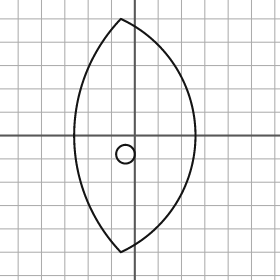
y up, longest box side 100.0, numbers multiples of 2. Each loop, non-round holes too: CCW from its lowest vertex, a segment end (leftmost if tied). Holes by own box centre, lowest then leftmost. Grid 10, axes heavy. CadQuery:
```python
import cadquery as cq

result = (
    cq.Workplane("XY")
    .moveTo(-6.0, -50.0)
    .threePointArc((26.0, 0.0), (-6.0, 50.0))
    .threePointArc((-26.0, 0.0), (-6.0, -50.0))
    .close()
    .moveTo(-4.0, -8.0)
    .circle(4.0)
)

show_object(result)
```